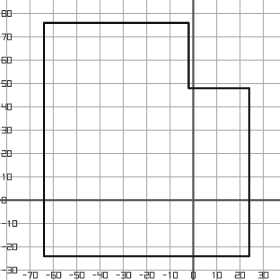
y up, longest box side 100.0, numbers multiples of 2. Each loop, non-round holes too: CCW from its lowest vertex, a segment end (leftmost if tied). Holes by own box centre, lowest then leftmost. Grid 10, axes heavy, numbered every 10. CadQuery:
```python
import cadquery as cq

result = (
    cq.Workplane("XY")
    .moveTo(-64.0, -24.0)
    .lineTo(24.0, -24.0)
    .lineTo(24.0, 48.0)
    .lineTo(-2.0, 48.0)
    .lineTo(-2.0, 76.0)
    .lineTo(-64.0, 76.0)
    .close()
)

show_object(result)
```